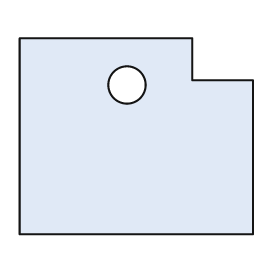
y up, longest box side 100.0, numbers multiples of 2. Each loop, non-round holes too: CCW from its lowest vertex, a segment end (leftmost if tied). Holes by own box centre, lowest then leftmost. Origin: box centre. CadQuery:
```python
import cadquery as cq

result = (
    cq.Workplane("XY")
    .moveTo(-50.0, -42.0)
    .lineTo(50.0, -42.0)
    .lineTo(50.0, 24.0)
    .lineTo(24.0, 24.0)
    .lineTo(24.0, 42.0)
    .lineTo(-50.0, 42.0)
    .close()
    .moveTo(-4.0, 22.0)
    .circle(8.0)
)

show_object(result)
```